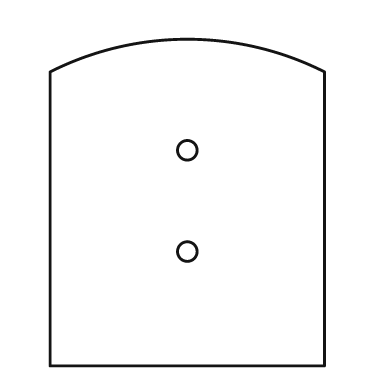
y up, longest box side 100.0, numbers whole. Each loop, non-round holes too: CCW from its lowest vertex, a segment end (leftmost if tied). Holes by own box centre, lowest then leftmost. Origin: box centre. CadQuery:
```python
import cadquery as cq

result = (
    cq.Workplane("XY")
    .moveTo(-42.0, -50.0)
    .lineTo(42.0, -50.0)
    .lineTo(42.0, 40.0)
    .threePointArc((0.0, 50.0), (-42.0, 40.0))
    .close()
    .moveTo(0.0, -15.0)
    .circle(3.0)
    .moveTo(0.0, 16.0)
    .circle(3.0)
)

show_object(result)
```